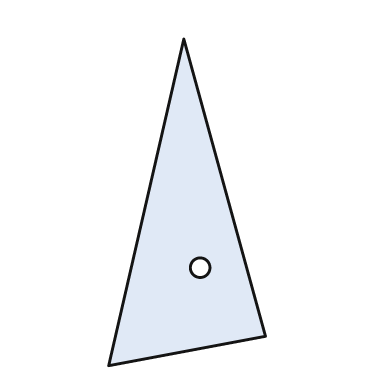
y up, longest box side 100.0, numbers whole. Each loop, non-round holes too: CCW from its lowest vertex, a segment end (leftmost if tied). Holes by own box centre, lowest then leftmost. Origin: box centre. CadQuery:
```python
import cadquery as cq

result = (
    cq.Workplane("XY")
    .moveTo(-24.0, -50.0)
    .lineTo(24.0, -41.0)
    .lineTo(-1.0, 50.0)
    .close()
    .moveTo(4.0, -20.0)
    .circle(3.0)
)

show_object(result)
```